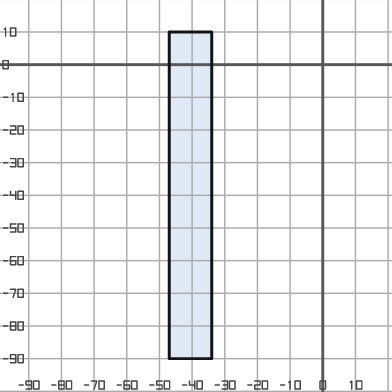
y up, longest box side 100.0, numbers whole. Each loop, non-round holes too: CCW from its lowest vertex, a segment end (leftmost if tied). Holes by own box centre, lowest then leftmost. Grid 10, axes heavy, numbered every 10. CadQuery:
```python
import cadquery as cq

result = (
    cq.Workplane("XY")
    .moveTo(-47.0, -90.0)
    .lineTo(-34.0, -90.0)
    .lineTo(-34.0, 10.0)
    .lineTo(-47.0, 10.0)
    .close()
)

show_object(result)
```